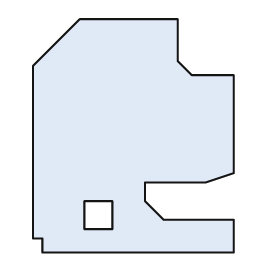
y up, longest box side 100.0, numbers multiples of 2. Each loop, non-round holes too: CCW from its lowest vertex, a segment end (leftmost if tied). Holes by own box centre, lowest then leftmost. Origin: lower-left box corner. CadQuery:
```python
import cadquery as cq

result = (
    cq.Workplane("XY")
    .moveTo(4.0, 0.0)
    .lineTo(86.0, 0.0)
    .lineTo(86.0, 14.0)
    .lineTo(56.0, 14.0)
    .lineTo(48.0, 22.0)
    .lineTo(48.0, 30.0)
    .lineTo(74.0, 30.0)
    .lineTo(86.0, 34.0)
    .lineTo(86.0, 76.0)
    .lineTo(68.0, 76.0)
    .lineTo(62.0, 82.0)
    .lineTo(62.0, 100.0)
    .lineTo(20.0, 100.0)
    .lineTo(0.0, 80.0)
    .lineTo(0.0, 6.0)
    .lineTo(4.0, 6.0)
    .close()
    .moveTo(22.0, 10.0)
    .lineTo(34.0, 10.0)
    .lineTo(34.0, 22.0)
    .lineTo(22.0, 22.0)
    .close()
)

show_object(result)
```